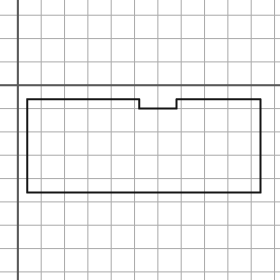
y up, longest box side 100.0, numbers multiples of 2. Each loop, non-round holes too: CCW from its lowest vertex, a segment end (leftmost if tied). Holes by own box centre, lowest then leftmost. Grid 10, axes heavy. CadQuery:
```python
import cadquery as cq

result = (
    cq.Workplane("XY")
    .moveTo(4.0, -46.0)
    .lineTo(104.0, -46.0)
    .lineTo(104.0, -6.0)
    .lineTo(68.0, -6.0)
    .lineTo(68.0, -10.0)
    .lineTo(52.0, -10.0)
    .lineTo(52.0, -6.0)
    .lineTo(4.0, -6.0)
    .close()
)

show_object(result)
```